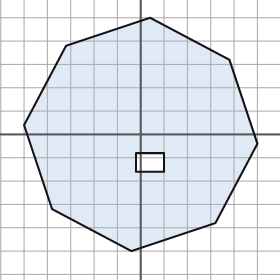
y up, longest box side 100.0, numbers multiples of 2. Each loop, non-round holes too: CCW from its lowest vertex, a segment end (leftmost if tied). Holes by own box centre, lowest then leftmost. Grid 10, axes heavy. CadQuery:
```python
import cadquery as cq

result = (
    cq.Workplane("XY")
    .moveTo(-4.0, -50.0)
    .lineTo(32.0, -38.0)
    .lineTo(50.0, -4.0)
    .lineTo(38.0, 32.0)
    .lineTo(4.0, 50.0)
    .lineTo(-32.0, 38.0)
    .lineTo(-50.0, 4.0)
    .lineTo(-38.0, -32.0)
    .close()
    .moveTo(-2.0, -16.0)
    .lineTo(10.0, -16.0)
    .lineTo(10.0, -8.0)
    .lineTo(-2.0, -8.0)
    .close()
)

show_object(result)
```